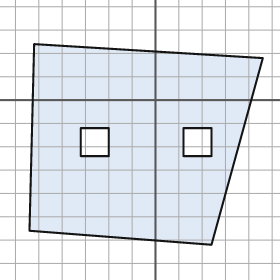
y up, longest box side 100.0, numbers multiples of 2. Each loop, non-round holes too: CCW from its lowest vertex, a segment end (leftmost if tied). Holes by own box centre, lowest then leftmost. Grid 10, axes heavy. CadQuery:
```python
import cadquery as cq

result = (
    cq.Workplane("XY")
    .moveTo(24.0, -62.0)
    .lineTo(46.0, 18.0)
    .lineTo(-52.0, 24.0)
    .lineTo(-54.0, -56.0)
    .close()
    .moveTo(-32.0, -24.0)
    .lineTo(-20.0, -24.0)
    .lineTo(-20.0, -12.0)
    .lineTo(-32.0, -12.0)
    .close()
    .moveTo(12.0, -24.0)
    .lineTo(24.0, -24.0)
    .lineTo(24.0, -12.0)
    .lineTo(12.0, -12.0)
    .close()
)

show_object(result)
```